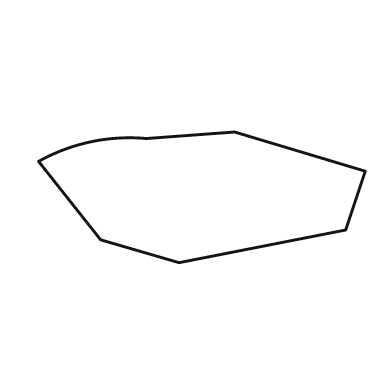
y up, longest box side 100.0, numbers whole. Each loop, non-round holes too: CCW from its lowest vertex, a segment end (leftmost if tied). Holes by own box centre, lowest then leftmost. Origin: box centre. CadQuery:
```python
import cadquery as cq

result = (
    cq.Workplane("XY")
    .moveTo(-7.0, -20.0)
    .lineTo(44.0, -10.0)
    .lineTo(50.0, 8.0)
    .lineTo(10.0, 20.0)
    .lineTo(-17.0, 18.0)
    .threePointArc((-34.0, 17.0), (-50.0, 11.0))
    .lineTo(-31.0, -13.0)
    .close()
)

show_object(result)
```